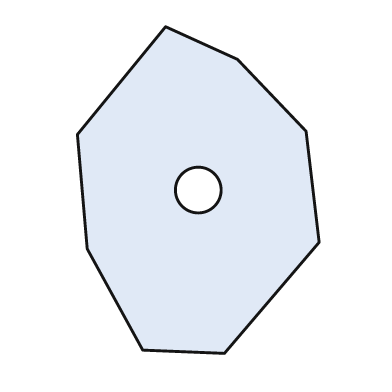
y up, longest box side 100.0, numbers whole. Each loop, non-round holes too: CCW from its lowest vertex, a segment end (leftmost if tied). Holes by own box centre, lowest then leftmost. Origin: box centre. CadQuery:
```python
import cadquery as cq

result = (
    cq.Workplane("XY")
    .moveTo(8.0, -50.0)
    .lineTo(37.0, -16.0)
    .lineTo(33.0, 18.0)
    .lineTo(12.0, 40.0)
    .lineTo(-10.0, 50.0)
    .lineTo(-37.0, 17.0)
    .lineTo(-34.0, -18.0)
    .lineTo(-17.0, -49.0)
    .close()
    .moveTo(0.0, 0.0)
    .circle(7.0)
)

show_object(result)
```